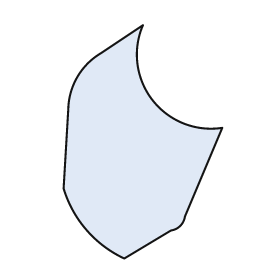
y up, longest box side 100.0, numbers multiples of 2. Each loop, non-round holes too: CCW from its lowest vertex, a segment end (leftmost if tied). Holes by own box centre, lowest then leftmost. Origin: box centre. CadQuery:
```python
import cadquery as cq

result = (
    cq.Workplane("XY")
    .moveTo(-8.0, -50.0)
    .lineTo(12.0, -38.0)
    .threePointArc((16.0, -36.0), (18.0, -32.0))
    .lineTo(34.0, 6.0)
    .threePointArc((4.0, 18.0), (0.0, 50.0))
    .lineTo(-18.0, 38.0)
    .threePointArc((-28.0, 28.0), (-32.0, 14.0))
    .lineTo(-34.0, -20.0)
    .threePointArc((-24.0, -38.0), (-8.0, -50.0))
    .close()
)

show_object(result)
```